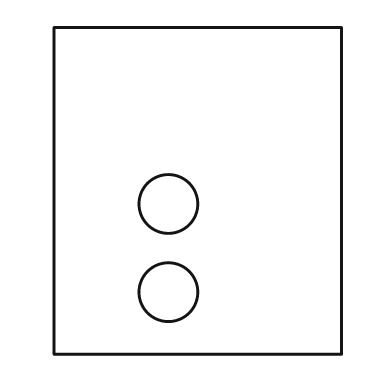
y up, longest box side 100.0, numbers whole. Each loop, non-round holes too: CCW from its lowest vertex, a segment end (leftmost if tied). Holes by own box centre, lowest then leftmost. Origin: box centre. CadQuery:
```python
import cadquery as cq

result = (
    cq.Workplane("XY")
    .moveTo(-44.0, -50.0)
    .lineTo(44.0, -50.0)
    .lineTo(44.0, 50.0)
    .lineTo(-44.0, 50.0)
    .close()
    .moveTo(-9.0, -31.0)
    .circle(9.0)
    .moveTo(-9.0, -4.0)
    .circle(9.0)
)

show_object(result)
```